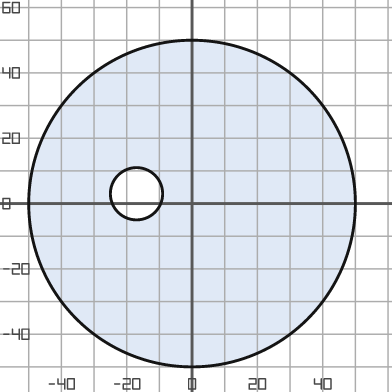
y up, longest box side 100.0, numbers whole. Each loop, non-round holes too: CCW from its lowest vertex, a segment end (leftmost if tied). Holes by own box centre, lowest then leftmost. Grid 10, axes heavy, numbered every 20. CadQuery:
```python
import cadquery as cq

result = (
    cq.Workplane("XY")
    .moveTo(0.0, 0.0)
    .circle(50.0)
    .moveTo(-17.0, 3.0)
    .circle(8.0)
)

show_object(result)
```